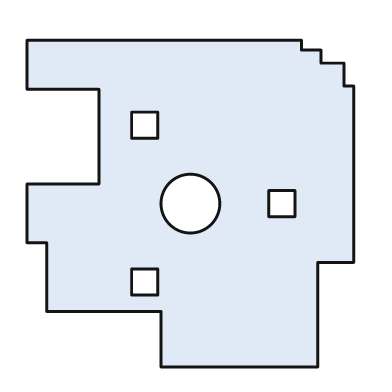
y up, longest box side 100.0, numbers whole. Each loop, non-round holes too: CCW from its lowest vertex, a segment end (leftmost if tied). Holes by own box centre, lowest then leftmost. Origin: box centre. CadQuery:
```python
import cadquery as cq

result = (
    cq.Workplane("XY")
    .moveTo(-9.0, -50.0)
    .lineTo(39.0, -50.0)
    .lineTo(39.0, -18.0)
    .lineTo(50.0, -18.0)
    .lineTo(50.0, 36.0)
    .lineTo(47.0, 36.0)
    .lineTo(47.0, 43.0)
    .lineTo(40.0, 43.0)
    .lineTo(40.0, 47.0)
    .lineTo(34.0, 47.0)
    .lineTo(34.0, 50.0)
    .lineTo(-50.0, 50.0)
    .lineTo(-50.0, 35.0)
    .lineTo(-28.0, 35.0)
    .lineTo(-28.0, 6.0)
    .lineTo(-50.0, 6.0)
    .lineTo(-50.0, -12.0)
    .lineTo(-44.0, -12.0)
    .lineTo(-44.0, -33.0)
    .lineTo(-9.0, -33.0)
    .close()
    .moveTo(-18.0, -28.0)
    .lineTo(-10.0, -28.0)
    .lineTo(-10.0, -20.0)
    .lineTo(-18.0, -20.0)
    .close()
    .moveTo(0.0, 0.0)
    .circle(9.0)
    .moveTo(24.0, -4.0)
    .lineTo(32.0, -4.0)
    .lineTo(32.0, 4.0)
    .lineTo(24.0, 4.0)
    .close()
    .moveTo(-18.0, 20.0)
    .lineTo(-10.0, 20.0)
    .lineTo(-10.0, 28.0)
    .lineTo(-18.0, 28.0)
    .close()
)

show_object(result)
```